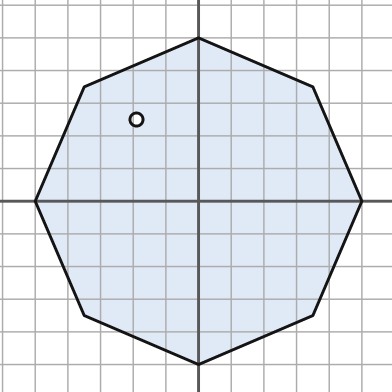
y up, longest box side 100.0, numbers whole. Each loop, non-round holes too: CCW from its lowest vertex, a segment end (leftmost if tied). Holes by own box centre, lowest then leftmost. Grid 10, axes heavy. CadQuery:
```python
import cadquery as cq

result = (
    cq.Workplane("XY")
    .moveTo(0.0, -50.0)
    .lineTo(35.0, -35.0)
    .lineTo(50.0, 0.0)
    .lineTo(35.0, 35.0)
    .lineTo(0.0, 50.0)
    .lineTo(-35.0, 35.0)
    .lineTo(-50.0, 0.0)
    .lineTo(-35.0, -35.0)
    .close()
    .moveTo(-19.0, 25.0)
    .circle(2.0)
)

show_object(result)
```